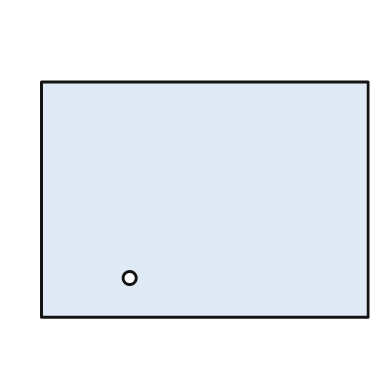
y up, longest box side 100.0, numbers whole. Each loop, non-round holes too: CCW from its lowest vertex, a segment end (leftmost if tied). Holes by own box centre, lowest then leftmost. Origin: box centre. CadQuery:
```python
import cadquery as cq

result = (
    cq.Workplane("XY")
    .moveTo(-50.0, -36.0)
    .lineTo(50.0, -36.0)
    .lineTo(50.0, 36.0)
    .lineTo(-50.0, 36.0)
    .close()
    .moveTo(-23.0, -24.0)
    .circle(2.0)
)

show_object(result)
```